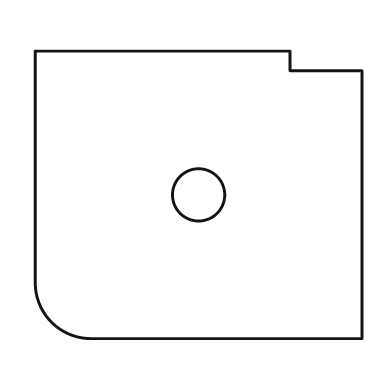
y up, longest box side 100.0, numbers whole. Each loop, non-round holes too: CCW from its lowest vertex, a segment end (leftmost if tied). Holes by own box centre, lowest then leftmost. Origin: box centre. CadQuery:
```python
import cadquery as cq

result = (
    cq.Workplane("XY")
    .moveTo(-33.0, -44.0)
    .lineTo(50.0, -44.0)
    .lineTo(50.0, 38.0)
    .lineTo(28.0, 38.0)
    .lineTo(28.0, 44.0)
    .lineTo(-50.0, 44.0)
    .lineTo(-50.0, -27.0)
    .threePointArc((-45.0, -39.0), (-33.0, -44.0))
    .close()
    .moveTo(0.0, 0.0)
    .circle(8.0)
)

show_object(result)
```